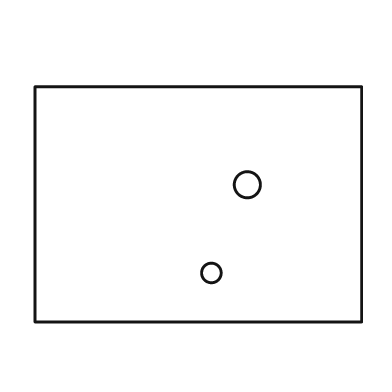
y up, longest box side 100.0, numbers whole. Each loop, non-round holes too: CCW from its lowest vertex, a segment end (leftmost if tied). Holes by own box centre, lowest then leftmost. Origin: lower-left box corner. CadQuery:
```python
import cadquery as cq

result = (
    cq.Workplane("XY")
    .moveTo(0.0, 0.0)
    .lineTo(100.0, 0.0)
    .lineTo(100.0, 72.0)
    .lineTo(0.0, 72.0)
    .close()
    .moveTo(54.0, 15.0)
    .circle(3.0)
    .moveTo(65.0, 42.0)
    .circle(4.0)
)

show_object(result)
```